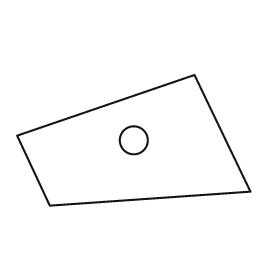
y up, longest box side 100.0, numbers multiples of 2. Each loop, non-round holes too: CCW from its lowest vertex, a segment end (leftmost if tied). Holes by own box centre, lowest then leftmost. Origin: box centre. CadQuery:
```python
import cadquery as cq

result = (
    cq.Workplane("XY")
    .moveTo(-36.0, -28.0)
    .lineTo(50.0, -22.0)
    .lineTo(26.0, 28.0)
    .lineTo(-50.0, 2.0)
    .close()
    .moveTo(0.0, 0.0)
    .circle(6.0)
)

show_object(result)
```